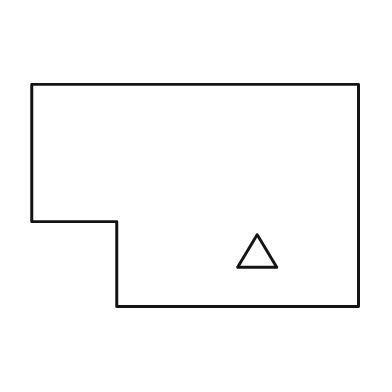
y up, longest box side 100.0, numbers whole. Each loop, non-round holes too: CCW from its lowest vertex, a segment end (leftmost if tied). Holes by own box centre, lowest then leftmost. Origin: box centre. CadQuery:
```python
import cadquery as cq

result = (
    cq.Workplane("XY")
    .moveTo(-24.0, -34.0)
    .lineTo(50.0, -34.0)
    .lineTo(50.0, 34.0)
    .lineTo(-50.0, 34.0)
    .lineTo(-50.0, -8.0)
    .lineTo(-24.0, -8.0)
    .close()
    .moveTo(13.0, -22.0)
    .lineTo(25.0, -22.0)
    .lineTo(19.0, -12.0)
    .close()
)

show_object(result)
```